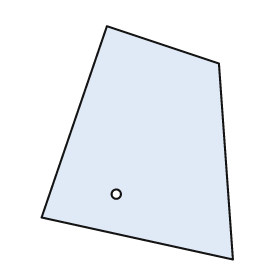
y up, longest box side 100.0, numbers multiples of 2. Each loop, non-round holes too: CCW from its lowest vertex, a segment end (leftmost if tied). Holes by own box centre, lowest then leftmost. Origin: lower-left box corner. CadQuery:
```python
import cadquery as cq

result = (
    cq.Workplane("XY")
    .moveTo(82.0, 0.0)
    .lineTo(76.0, 84.0)
    .lineTo(28.0, 100.0)
    .lineTo(0.0, 18.0)
    .close()
    .moveTo(32.0, 28.0)
    .circle(2.0)
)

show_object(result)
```